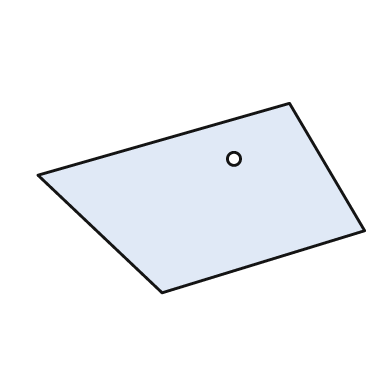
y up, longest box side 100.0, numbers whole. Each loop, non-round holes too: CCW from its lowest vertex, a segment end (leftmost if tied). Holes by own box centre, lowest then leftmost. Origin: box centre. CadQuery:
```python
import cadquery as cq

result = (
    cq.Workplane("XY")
    .moveTo(-12.0, -29.0)
    .lineTo(50.0, -10.0)
    .lineTo(27.0, 29.0)
    .lineTo(-50.0, 7.0)
    .close()
    .moveTo(10.0, 12.0)
    .circle(2.0)
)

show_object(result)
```